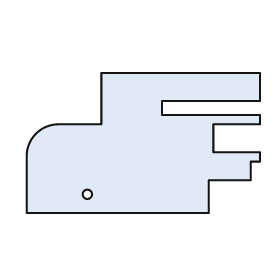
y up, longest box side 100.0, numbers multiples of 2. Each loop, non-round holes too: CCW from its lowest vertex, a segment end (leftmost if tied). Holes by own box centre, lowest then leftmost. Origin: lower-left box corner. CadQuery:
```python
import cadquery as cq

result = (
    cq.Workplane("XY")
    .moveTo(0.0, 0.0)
    .lineTo(78.0, 0.0)
    .lineTo(78.0, 14.0)
    .lineTo(96.0, 14.0)
    .lineTo(96.0, 22.0)
    .lineTo(100.0, 22.0)
    .lineTo(100.0, 26.0)
    .lineTo(80.0, 26.0)
    .lineTo(80.0, 38.0)
    .lineTo(100.0, 38.0)
    .lineTo(100.0, 42.0)
    .lineTo(58.0, 42.0)
    .lineTo(58.0, 48.0)
    .lineTo(100.0, 48.0)
    .lineTo(100.0, 60.0)
    .lineTo(32.0, 60.0)
    .lineTo(32.0, 38.0)
    .lineTo(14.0, 38.0)
    .threePointArc((4.0, 34.0), (0.0, 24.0))
    .close()
    .moveTo(26.0, 8.0)
    .circle(2.0)
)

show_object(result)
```